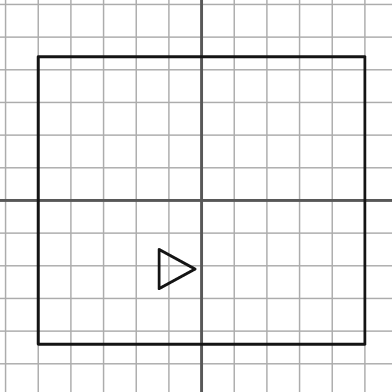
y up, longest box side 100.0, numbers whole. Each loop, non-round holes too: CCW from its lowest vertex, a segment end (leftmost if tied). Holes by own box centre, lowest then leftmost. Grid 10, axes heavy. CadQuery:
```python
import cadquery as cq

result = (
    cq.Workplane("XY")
    .moveTo(-50.0, -44.0)
    .lineTo(50.0, -44.0)
    .lineTo(50.0, 44.0)
    .lineTo(-50.0, 44.0)
    .close()
    .moveTo(-13.0, -27.0)
    .lineTo(-2.0, -21.0)
    .lineTo(-13.0, -15.0)
    .close()
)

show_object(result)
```